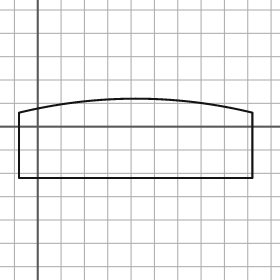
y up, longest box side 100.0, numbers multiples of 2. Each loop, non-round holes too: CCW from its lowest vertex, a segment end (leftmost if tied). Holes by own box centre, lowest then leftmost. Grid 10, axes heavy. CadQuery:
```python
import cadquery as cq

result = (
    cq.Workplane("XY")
    .moveTo(-8.0, -22.0)
    .lineTo(92.0, -22.0)
    .lineTo(92.0, 6.0)
    .threePointArc((42.0, 12.0), (-8.0, 6.0))
    .close()
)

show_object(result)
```